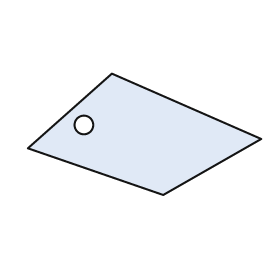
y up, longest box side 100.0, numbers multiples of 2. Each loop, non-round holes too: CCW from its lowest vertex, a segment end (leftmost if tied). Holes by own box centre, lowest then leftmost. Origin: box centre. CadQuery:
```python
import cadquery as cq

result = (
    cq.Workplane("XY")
    .moveTo(8.0, -26.0)
    .lineTo(50.0, -2.0)
    .lineTo(-14.0, 26.0)
    .lineTo(-50.0, -6.0)
    .close()
    .moveTo(-26.0, 4.0)
    .circle(4.0)
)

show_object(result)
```